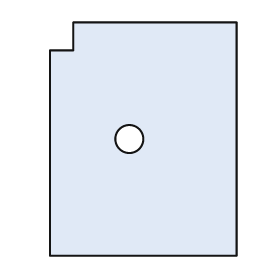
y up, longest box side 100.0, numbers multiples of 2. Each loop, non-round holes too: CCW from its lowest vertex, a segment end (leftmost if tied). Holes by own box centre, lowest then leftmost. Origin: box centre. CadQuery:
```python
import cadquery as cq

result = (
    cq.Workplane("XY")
    .moveTo(-40.0, -50.0)
    .lineTo(40.0, -50.0)
    .lineTo(40.0, 50.0)
    .lineTo(-30.0, 50.0)
    .lineTo(-30.0, 38.0)
    .lineTo(-40.0, 38.0)
    .close()
    .moveTo(-6.0, 0.0)
    .circle(6.0)
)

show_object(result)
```